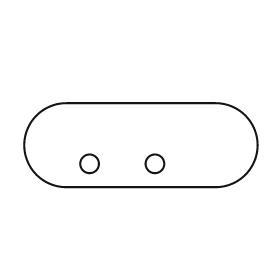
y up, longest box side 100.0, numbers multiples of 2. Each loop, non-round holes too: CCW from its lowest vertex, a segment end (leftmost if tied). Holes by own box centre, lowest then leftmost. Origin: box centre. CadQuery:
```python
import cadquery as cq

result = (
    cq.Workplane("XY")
    .moveTo(-32.0, -18.0)
    .lineTo(32.0, -18.0)
    .threePointArc((50.0, 0.0), (32.0, 18.0))
    .lineTo(-32.0, 18.0)
    .threePointArc((-50.0, 0.0), (-32.0, -18.0))
    .close()
    .moveTo(-22.0, -8.0)
    .circle(4.0)
    .moveTo(6.0, -8.0)
    .circle(4.0)
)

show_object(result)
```